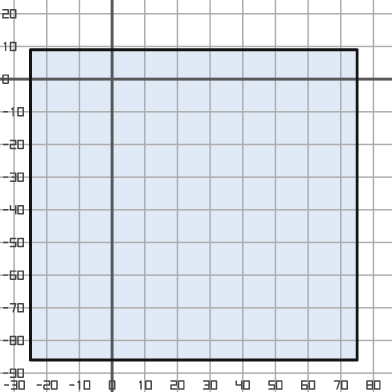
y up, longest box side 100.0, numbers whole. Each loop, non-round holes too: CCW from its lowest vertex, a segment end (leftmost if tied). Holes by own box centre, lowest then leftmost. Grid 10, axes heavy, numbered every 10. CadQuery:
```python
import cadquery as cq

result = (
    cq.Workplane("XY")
    .moveTo(-25.0, -86.0)
    .lineTo(75.0, -86.0)
    .lineTo(75.0, 9.0)
    .lineTo(-25.0, 9.0)
    .close()
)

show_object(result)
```